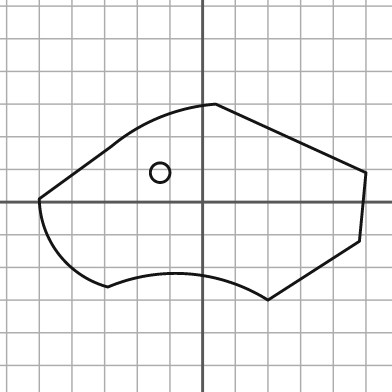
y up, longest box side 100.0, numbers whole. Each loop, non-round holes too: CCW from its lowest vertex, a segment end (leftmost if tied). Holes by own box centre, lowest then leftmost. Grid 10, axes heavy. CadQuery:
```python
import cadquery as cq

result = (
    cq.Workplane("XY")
    .moveTo(20.0, -30.0)
    .lineTo(48.0, -12.0)
    .lineTo(50.0, 9.0)
    .lineTo(4.0, 30.0)
    .threePointArc((-13.0, 26.0), (-28.0, 17.0))
    .lineTo(-50.0, 1.0)
    .threePointArc((-44.0, -16.0), (-29.0, -26.0))
    .threePointArc((-4.0, -22.0), (20.0, -30.0))
    .close()
    .moveTo(-13.0, 9.0)
    .circle(3.0)
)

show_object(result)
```